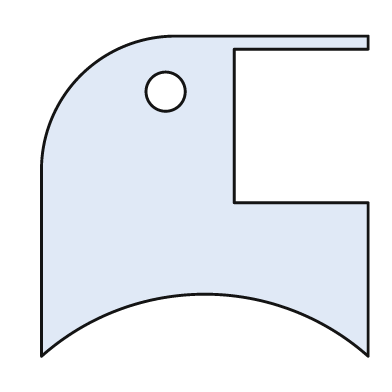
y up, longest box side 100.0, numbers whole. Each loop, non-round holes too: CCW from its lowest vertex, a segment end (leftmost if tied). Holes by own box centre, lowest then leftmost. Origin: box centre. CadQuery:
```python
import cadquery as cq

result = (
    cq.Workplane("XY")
    .moveTo(-50.0, -49.0)
    .threePointArc((0.0, -30.0), (50.0, -49.0))
    .lineTo(50.0, -2.0)
    .lineTo(9.0, -2.0)
    .lineTo(9.0, 45.0)
    .lineTo(50.0, 45.0)
    .lineTo(50.0, 49.0)
    .lineTo(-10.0, 49.0)
    .threePointArc((-38.0, 37.0), (-50.0, 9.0))
    .close()
    .moveTo(-12.0, 32.0)
    .circle(6.0)
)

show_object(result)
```